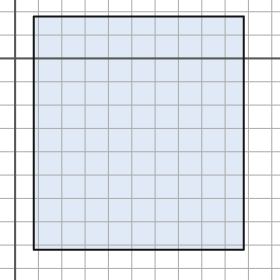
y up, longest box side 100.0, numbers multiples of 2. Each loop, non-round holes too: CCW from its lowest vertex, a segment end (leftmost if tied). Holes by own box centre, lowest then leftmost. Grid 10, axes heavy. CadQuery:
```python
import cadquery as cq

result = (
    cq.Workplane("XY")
    .moveTo(8.0, -82.0)
    .lineTo(98.0, -82.0)
    .lineTo(98.0, 18.0)
    .lineTo(8.0, 18.0)
    .close()
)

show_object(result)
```